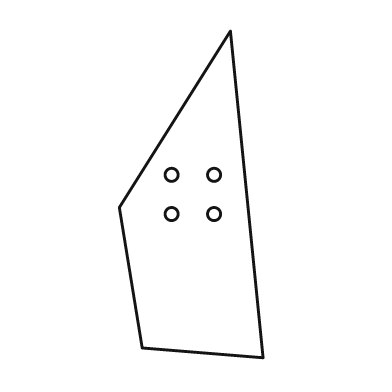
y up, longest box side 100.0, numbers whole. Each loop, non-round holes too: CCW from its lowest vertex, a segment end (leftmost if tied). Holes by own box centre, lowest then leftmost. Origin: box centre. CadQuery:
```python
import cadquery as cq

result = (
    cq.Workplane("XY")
    .moveTo(22.0, -50.0)
    .lineTo(12.0, 50.0)
    .lineTo(-22.0, -4.0)
    .lineTo(-15.0, -47.0)
    .close()
    .moveTo(-6.0, -6.0)
    .circle(2.0)
    .moveTo(7.0, -6.0)
    .circle(2.0)
    .moveTo(-6.0, 6.0)
    .circle(2.0)
    .moveTo(7.0, 6.0)
    .circle(2.0)
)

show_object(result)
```